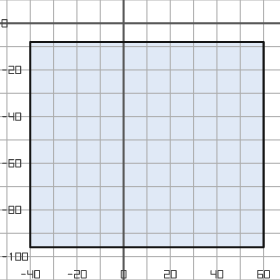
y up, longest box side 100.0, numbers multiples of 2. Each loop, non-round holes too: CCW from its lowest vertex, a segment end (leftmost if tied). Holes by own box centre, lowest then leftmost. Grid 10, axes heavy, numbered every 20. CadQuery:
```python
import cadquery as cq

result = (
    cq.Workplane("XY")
    .moveTo(-40.0, -96.0)
    .lineTo(60.0, -96.0)
    .lineTo(60.0, -8.0)
    .lineTo(-40.0, -8.0)
    .close()
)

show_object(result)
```